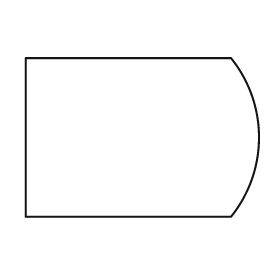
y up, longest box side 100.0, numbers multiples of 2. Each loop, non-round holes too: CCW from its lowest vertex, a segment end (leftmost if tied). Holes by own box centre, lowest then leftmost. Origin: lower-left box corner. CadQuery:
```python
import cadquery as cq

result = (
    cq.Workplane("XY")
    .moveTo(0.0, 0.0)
    .lineTo(88.0, 0.0)
    .threePointArc((100.0, 34.0), (88.0, 68.0))
    .lineTo(0.0, 68.0)
    .close()
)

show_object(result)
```